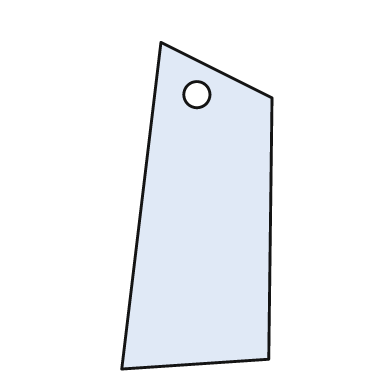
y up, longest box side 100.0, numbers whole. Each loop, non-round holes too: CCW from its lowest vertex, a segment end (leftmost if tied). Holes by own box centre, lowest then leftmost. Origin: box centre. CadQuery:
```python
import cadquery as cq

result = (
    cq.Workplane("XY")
    .moveTo(-23.0, -50.0)
    .lineTo(22.0, -47.0)
    .lineTo(23.0, 33.0)
    .lineTo(-11.0, 50.0)
    .close()
    .moveTo(0.0, 34.0)
    .circle(4.0)
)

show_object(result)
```